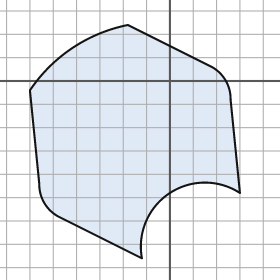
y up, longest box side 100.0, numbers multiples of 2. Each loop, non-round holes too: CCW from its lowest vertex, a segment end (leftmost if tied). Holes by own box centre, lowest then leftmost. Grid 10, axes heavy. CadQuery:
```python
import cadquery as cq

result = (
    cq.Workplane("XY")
    .moveTo(-12.0, -76.0)
    .threePointArc((0.0, -48.0), (30.0, -48.0))
    .lineTo(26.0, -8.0)
    .threePointArc((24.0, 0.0), (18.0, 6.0))
    .lineTo(-18.0, 24.0)
    .threePointArc((-42.0, 14.0), (-60.0, -4.0))
    .lineTo(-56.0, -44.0)
    .threePointArc((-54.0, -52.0), (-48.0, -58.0))
    .close()
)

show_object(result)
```